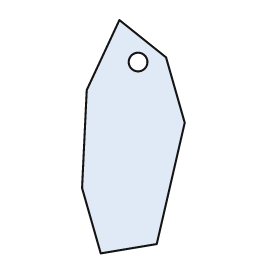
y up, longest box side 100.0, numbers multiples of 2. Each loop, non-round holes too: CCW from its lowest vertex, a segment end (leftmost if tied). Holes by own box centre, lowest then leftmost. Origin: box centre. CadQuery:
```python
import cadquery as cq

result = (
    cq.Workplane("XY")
    .moveTo(-14.0, -50.0)
    .lineTo(10.0, -46.0)
    .lineTo(22.0, 6.0)
    .lineTo(14.0, 34.0)
    .lineTo(-6.0, 50.0)
    .lineTo(-20.0, 20.0)
    .lineTo(-22.0, -22.0)
    .close()
    .moveTo(2.0, 32.0)
    .circle(4.0)
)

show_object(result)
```